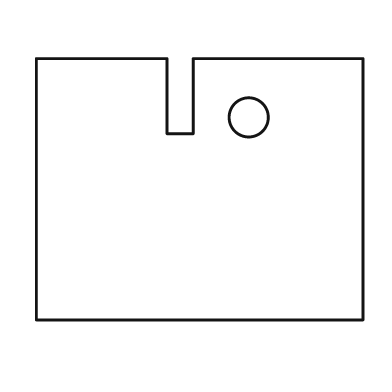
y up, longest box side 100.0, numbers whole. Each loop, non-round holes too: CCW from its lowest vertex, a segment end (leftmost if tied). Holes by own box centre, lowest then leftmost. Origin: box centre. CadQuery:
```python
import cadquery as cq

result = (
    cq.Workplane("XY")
    .moveTo(-50.0, -40.0)
    .lineTo(50.0, -40.0)
    .lineTo(50.0, 40.0)
    .lineTo(-2.0, 40.0)
    .lineTo(-2.0, 17.0)
    .lineTo(-10.0, 17.0)
    .lineTo(-10.0, 40.0)
    .lineTo(-50.0, 40.0)
    .close()
    .moveTo(15.0, 22.0)
    .circle(6.0)
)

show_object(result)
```